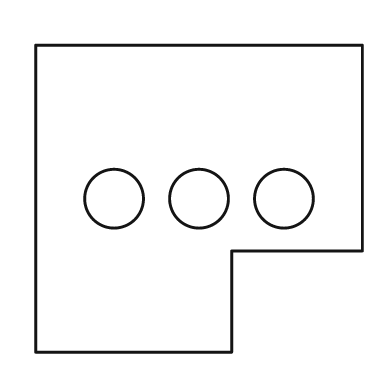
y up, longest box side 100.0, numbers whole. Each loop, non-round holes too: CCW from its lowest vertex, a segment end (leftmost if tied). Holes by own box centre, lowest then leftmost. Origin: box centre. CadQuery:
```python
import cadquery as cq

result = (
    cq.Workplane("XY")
    .moveTo(-50.0, -47.0)
    .lineTo(10.0, -47.0)
    .lineTo(10.0, -16.0)
    .lineTo(50.0, -16.0)
    .lineTo(50.0, 47.0)
    .lineTo(-50.0, 47.0)
    .close()
    .moveTo(-26.0, 0.0)
    .circle(9.0)
    .moveTo(0.0, 0.0)
    .circle(9.0)
    .moveTo(26.0, 0.0)
    .circle(9.0)
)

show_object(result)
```